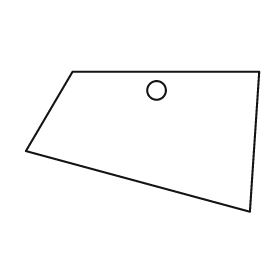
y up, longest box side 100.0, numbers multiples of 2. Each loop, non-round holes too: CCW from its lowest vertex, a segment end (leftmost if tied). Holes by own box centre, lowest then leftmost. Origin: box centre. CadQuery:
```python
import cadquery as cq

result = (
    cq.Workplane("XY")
    .moveTo(46.0, -30.0)
    .lineTo(50.0, 30.0)
    .lineTo(-30.0, 30.0)
    .lineTo(-50.0, -4.0)
    .close()
    .moveTo(6.0, 22.0)
    .circle(4.0)
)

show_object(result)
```